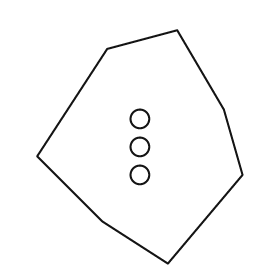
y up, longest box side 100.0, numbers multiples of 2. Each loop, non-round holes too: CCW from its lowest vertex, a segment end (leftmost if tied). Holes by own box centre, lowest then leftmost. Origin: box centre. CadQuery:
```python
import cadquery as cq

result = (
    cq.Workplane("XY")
    .moveTo(12.0, -50.0)
    .lineTo(44.0, -12.0)
    .lineTo(36.0, 16.0)
    .lineTo(16.0, 50.0)
    .lineTo(-14.0, 42.0)
    .lineTo(-44.0, -4.0)
    .lineTo(-16.0, -32.0)
    .close()
    .moveTo(0.0, -12.0)
    .circle(4.0)
    .moveTo(0.0, 0.0)
    .circle(4.0)
    .moveTo(0.0, 12.0)
    .circle(4.0)
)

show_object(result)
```